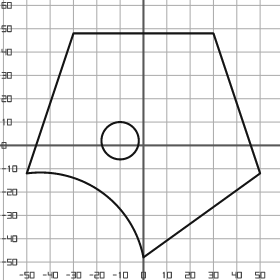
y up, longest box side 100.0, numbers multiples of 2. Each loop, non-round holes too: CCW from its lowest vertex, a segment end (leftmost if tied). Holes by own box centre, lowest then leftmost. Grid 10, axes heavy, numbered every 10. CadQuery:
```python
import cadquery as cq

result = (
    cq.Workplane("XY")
    .moveTo(0.0, -48.0)
    .lineTo(50.0, -12.0)
    .lineTo(30.0, 48.0)
    .lineTo(-30.0, 48.0)
    .lineTo(-50.0, -12.0)
    .threePointArc((-18.0, -20.0), (0.0, -48.0))
    .close()
    .moveTo(-10.0, 2.0)
    .circle(8.0)
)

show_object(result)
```